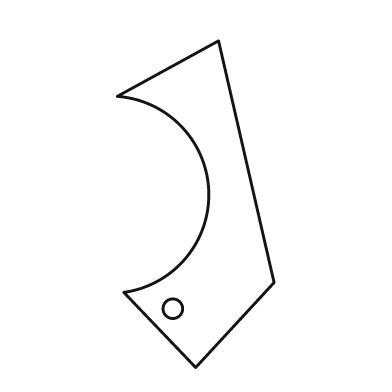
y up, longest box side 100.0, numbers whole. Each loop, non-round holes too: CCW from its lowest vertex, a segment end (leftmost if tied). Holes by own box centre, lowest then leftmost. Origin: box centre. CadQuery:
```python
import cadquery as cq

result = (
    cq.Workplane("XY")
    .moveTo(0.0, -50.0)
    .lineTo(24.0, -24.0)
    .lineTo(7.0, 50.0)
    .lineTo(-24.0, 33.0)
    .threePointArc((4.0, 4.0), (-22.0, -27.0))
    .close()
    .moveTo(-7.0, -32.0)
    .circle(3.0)
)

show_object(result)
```